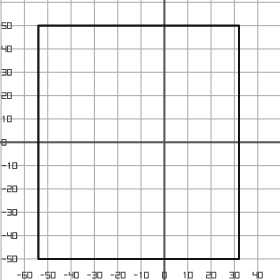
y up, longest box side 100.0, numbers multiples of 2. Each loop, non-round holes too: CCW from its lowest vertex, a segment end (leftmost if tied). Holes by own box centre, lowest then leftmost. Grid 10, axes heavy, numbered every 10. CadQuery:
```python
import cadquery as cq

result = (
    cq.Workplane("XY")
    .moveTo(-54.0, -50.0)
    .lineTo(32.0, -50.0)
    .lineTo(32.0, 50.0)
    .lineTo(-54.0, 50.0)
    .close()
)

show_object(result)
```